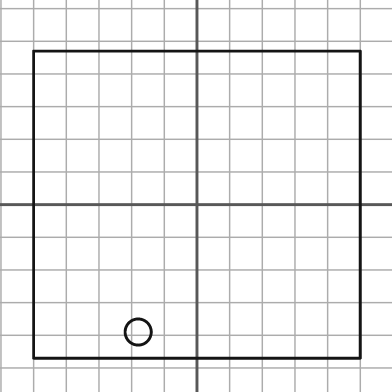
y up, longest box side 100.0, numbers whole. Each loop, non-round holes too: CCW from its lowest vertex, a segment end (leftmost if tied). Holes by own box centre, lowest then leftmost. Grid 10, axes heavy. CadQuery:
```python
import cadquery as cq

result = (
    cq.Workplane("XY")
    .moveTo(-50.0, -47.0)
    .lineTo(50.0, -47.0)
    .lineTo(50.0, 47.0)
    .lineTo(-50.0, 47.0)
    .close()
    .moveTo(-18.0, -39.0)
    .circle(4.0)
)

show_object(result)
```